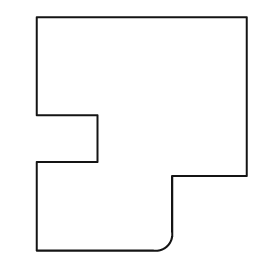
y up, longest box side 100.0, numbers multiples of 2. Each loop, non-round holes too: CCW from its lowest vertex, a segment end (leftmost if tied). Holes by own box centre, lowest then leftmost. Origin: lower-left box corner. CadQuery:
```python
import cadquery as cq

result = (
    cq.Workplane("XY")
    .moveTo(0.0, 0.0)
    .lineTo(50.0, 0.0)
    .threePointArc((56.0, 2.0), (58.0, 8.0))
    .lineTo(58.0, 32.0)
    .lineTo(90.0, 32.0)
    .lineTo(90.0, 100.0)
    .lineTo(0.0, 100.0)
    .lineTo(0.0, 58.0)
    .lineTo(26.0, 58.0)
    .lineTo(26.0, 38.0)
    .lineTo(0.0, 38.0)
    .close()
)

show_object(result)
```